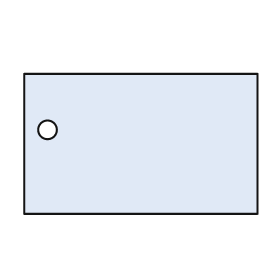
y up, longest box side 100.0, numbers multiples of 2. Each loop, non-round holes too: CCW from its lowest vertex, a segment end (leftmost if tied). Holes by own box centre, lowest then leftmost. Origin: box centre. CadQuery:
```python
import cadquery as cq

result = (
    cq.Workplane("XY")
    .moveTo(-50.0, -30.0)
    .lineTo(50.0, -30.0)
    .lineTo(50.0, 30.0)
    .lineTo(-50.0, 30.0)
    .close()
    .moveTo(-40.0, 6.0)
    .circle(4.0)
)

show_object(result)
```